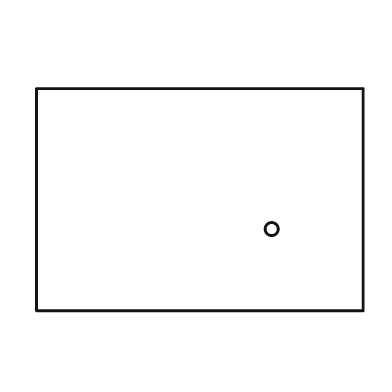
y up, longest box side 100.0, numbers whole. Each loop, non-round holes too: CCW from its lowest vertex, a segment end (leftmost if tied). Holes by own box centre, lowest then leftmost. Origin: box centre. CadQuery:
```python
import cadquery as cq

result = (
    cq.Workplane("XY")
    .moveTo(-50.0, -34.0)
    .lineTo(50.0, -34.0)
    .lineTo(50.0, 34.0)
    .lineTo(-50.0, 34.0)
    .close()
    .moveTo(22.0, -9.0)
    .circle(2.0)
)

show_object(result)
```